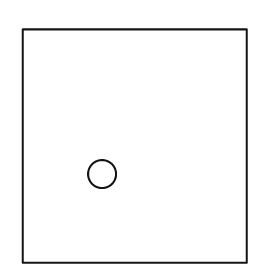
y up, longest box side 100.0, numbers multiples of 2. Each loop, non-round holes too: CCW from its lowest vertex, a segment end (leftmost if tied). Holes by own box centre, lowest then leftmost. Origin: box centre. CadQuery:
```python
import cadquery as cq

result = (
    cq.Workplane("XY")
    .moveTo(-48.0, -50.0)
    .lineTo(48.0, -50.0)
    .lineTo(48.0, 50.0)
    .lineTo(-48.0, 50.0)
    .close()
    .moveTo(-14.0, -12.0)
    .circle(6.0)
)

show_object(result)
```